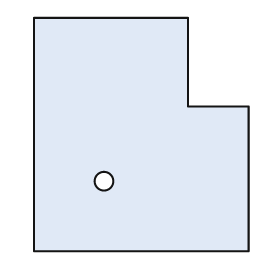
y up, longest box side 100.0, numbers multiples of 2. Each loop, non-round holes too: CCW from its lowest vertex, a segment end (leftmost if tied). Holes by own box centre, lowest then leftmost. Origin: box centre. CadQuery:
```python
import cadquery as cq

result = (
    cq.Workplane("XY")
    .moveTo(-46.0, -50.0)
    .lineTo(46.0, -50.0)
    .lineTo(46.0, 12.0)
    .lineTo(20.0, 12.0)
    .lineTo(20.0, 50.0)
    .lineTo(-46.0, 50.0)
    .close()
    .moveTo(-16.0, -20.0)
    .circle(4.0)
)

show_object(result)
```